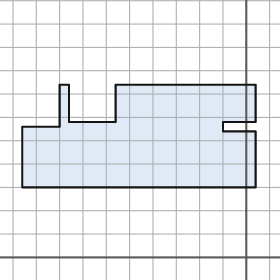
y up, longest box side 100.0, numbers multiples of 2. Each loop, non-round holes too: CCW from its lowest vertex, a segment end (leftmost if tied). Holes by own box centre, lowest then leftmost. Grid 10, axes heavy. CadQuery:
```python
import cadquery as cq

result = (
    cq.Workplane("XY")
    .moveTo(-96.0, 30.0)
    .lineTo(4.0, 30.0)
    .lineTo(4.0, 54.0)
    .lineTo(-10.0, 54.0)
    .lineTo(-10.0, 58.0)
    .lineTo(4.0, 58.0)
    .lineTo(4.0, 74.0)
    .lineTo(-56.0, 74.0)
    .lineTo(-56.0, 58.0)
    .lineTo(-76.0, 58.0)
    .lineTo(-76.0, 74.0)
    .lineTo(-80.0, 74.0)
    .lineTo(-80.0, 56.0)
    .lineTo(-96.0, 56.0)
    .close()
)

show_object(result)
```